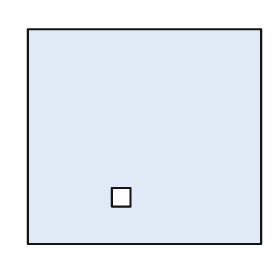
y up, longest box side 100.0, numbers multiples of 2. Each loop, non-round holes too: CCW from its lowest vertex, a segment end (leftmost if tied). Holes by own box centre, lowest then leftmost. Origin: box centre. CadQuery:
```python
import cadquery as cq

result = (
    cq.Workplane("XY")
    .moveTo(-50.0, -46.0)
    .lineTo(50.0, -46.0)
    .lineTo(50.0, 46.0)
    .lineTo(-50.0, 46.0)
    .close()
    .moveTo(-14.0, -30.0)
    .lineTo(-6.0, -30.0)
    .lineTo(-6.0, -22.0)
    .lineTo(-14.0, -22.0)
    .close()
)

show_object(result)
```